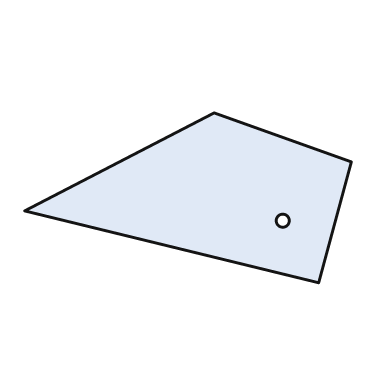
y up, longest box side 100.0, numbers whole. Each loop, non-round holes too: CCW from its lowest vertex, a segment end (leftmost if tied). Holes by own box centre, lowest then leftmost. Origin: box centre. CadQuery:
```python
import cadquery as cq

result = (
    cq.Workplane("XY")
    .moveTo(40.0, -26.0)
    .lineTo(50.0, 11.0)
    .lineTo(8.0, 26.0)
    .lineTo(-50.0, -4.0)
    .close()
    .moveTo(29.0, -7.0)
    .circle(2.0)
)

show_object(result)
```